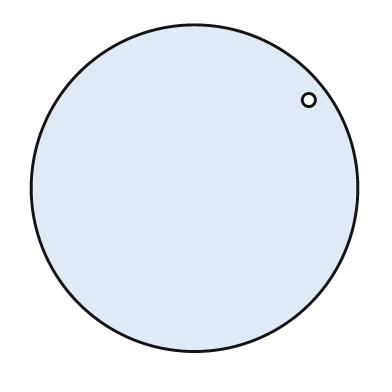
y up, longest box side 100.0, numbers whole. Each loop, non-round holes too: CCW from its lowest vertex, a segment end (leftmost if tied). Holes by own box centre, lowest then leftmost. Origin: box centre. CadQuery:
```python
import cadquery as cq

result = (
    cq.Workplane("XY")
    .moveTo(0.0, 0.0)
    .circle(50.0)
    .moveTo(35.0, 27.0)
    .circle(2.0)
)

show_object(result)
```